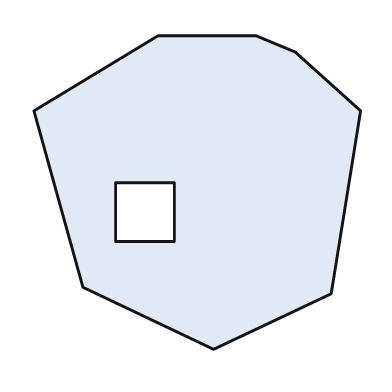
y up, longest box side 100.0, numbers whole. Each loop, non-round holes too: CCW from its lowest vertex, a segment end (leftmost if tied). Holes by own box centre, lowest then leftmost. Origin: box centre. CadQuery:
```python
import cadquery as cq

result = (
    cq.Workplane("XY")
    .moveTo(5.0, -48.0)
    .lineTo(41.0, -31.0)
    .lineTo(50.0, 25.0)
    .lineTo(30.0, 43.0)
    .lineTo(18.0, 48.0)
    .lineTo(-12.0, 48.0)
    .lineTo(-50.0, 25.0)
    .lineTo(-35.0, -29.0)
    .close()
    .moveTo(-25.0, -15.0)
    .lineTo(-7.0, -15.0)
    .lineTo(-7.0, 3.0)
    .lineTo(-25.0, 3.0)
    .close()
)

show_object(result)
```